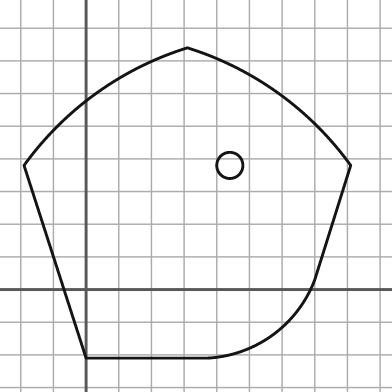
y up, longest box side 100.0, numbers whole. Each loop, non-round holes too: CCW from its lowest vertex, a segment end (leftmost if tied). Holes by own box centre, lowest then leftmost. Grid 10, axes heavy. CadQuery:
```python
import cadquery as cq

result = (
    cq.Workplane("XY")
    .moveTo(0.0, -21.0)
    .lineTo(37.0, -21.0)
    .threePointArc((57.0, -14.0), (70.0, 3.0))
    .lineTo(81.0, 38.0)
    .threePointArc((59.0, 60.0), (31.0, 74.0))
    .threePointArc((3.0, 60.0), (-19.0, 38.0))
    .close()
    .moveTo(44.0, 38.0)
    .circle(4.0)
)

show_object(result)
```